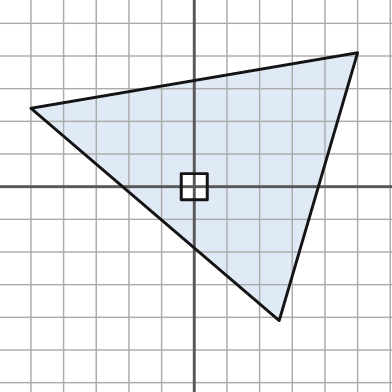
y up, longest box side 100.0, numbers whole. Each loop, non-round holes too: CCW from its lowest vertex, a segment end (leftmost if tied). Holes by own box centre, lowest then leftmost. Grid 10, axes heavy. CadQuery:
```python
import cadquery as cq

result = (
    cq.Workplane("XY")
    .moveTo(26.0, -41.0)
    .lineTo(50.0, 41.0)
    .lineTo(-50.0, 24.0)
    .close()
    .moveTo(-4.0, -4.0)
    .lineTo(4.0, -4.0)
    .lineTo(4.0, 4.0)
    .lineTo(-4.0, 4.0)
    .close()
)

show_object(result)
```